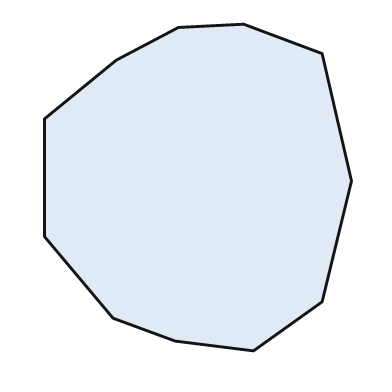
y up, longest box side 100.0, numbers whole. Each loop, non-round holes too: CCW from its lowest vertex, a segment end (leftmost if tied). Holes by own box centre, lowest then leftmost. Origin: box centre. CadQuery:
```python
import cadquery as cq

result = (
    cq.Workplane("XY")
    .moveTo(17.0, -50.0)
    .lineTo(38.0, -35.0)
    .lineTo(47.0, 2.0)
    .lineTo(38.0, 41.0)
    .lineTo(14.0, 50.0)
    .lineTo(-6.0, 49.0)
    .lineTo(-25.0, 39.0)
    .lineTo(-47.0, 21.0)
    .lineTo(-47.0, -15.0)
    .lineTo(-26.0, -40.0)
    .lineTo(-7.0, -47.0)
    .close()
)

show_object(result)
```